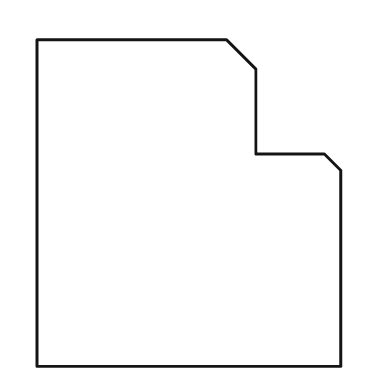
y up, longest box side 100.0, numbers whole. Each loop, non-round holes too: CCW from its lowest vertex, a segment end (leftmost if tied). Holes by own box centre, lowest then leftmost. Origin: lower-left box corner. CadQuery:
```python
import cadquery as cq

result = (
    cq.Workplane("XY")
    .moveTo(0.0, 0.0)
    .lineTo(93.0, 0.0)
    .lineTo(93.0, 60.0)
    .lineTo(88.0, 65.0)
    .lineTo(67.0, 65.0)
    .lineTo(67.0, 91.0)
    .lineTo(58.0, 100.0)
    .lineTo(0.0, 100.0)
    .close()
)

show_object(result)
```